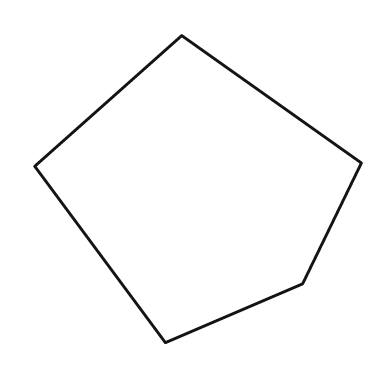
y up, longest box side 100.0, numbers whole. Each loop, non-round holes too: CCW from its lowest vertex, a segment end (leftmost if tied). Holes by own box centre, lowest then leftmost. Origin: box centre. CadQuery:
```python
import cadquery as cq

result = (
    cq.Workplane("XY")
    .moveTo(-10.0, -47.0)
    .lineTo(32.0, -29.0)
    .lineTo(50.0, 8.0)
    .lineTo(-5.0, 47.0)
    .lineTo(-50.0, 7.0)
    .close()
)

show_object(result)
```